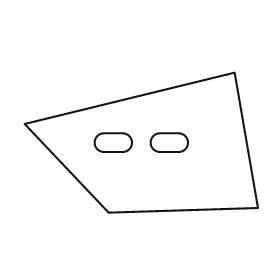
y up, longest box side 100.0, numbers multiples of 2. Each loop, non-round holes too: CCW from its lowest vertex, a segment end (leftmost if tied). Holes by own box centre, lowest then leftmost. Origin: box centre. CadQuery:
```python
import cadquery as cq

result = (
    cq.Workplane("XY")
    .moveTo(-14.0, -30.0)
    .lineTo(50.0, -28.0)
    .lineTo(40.0, 30.0)
    .lineTo(-50.0, 8.0)
    .close()
    .moveTo(-16.0, -4.0)
    .lineTo(-8.0, -4.0)
    .threePointArc((-4.0, 0.0), (-8.0, 4.0))
    .lineTo(-16.0, 4.0)
    .threePointArc((-20.0, 0.0), (-16.0, -4.0))
    .close()
    .moveTo(8.0, -4.0)
    .lineTo(16.0, -4.0)
    .threePointArc((20.0, 0.0), (16.0, 4.0))
    .lineTo(8.0, 4.0)
    .threePointArc((4.0, 0.0), (8.0, -4.0))
    .close()
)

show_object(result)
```